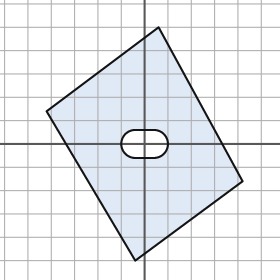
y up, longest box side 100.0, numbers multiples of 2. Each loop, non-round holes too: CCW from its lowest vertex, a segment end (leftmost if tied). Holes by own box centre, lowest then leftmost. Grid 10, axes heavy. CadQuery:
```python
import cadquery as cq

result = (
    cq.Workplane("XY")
    .moveTo(-4.0, -50.0)
    .lineTo(42.0, -16.0)
    .lineTo(6.0, 50.0)
    .lineTo(-42.0, 14.0)
    .close()
    .moveTo(-4.0, -6.0)
    .lineTo(4.0, -6.0)
    .threePointArc((10.0, 0.0), (4.0, 6.0))
    .lineTo(-4.0, 6.0)
    .threePointArc((-10.0, 0.0), (-4.0, -6.0))
    .close()
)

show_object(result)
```